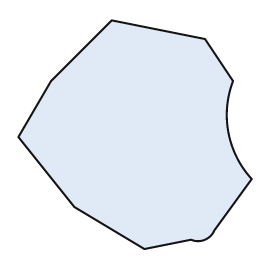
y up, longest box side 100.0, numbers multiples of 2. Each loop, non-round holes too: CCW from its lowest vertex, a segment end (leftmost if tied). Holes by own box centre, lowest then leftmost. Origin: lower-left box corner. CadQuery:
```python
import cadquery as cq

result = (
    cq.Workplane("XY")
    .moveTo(54.0, 0.0)
    .lineTo(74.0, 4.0)
    .threePointArc((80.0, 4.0), (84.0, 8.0))
    .lineTo(100.0, 30.0)
    .threePointArc((90.0, 50.0), (92.0, 72.0))
    .lineTo(80.0, 90.0)
    .lineTo(40.0, 98.0)
    .lineTo(14.0, 72.0)
    .lineTo(0.0, 48.0)
    .lineTo(24.0, 18.0)
    .close()
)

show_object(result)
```